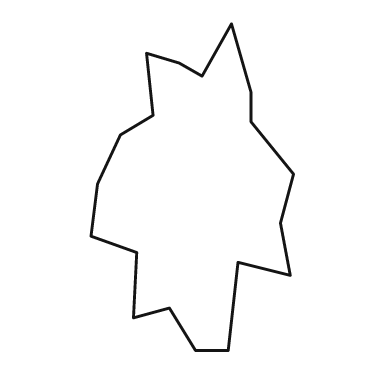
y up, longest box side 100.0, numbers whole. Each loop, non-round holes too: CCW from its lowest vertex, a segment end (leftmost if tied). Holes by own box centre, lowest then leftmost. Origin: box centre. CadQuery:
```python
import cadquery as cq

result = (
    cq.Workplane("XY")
    .moveTo(1.0, -50.0)
    .lineTo(11.0, -50.0)
    .lineTo(14.0, -23.0)
    .lineTo(30.0, -27.0)
    .lineTo(27.0, -11.0)
    .lineTo(31.0, 4.0)
    .lineTo(18.0, 20.0)
    .lineTo(18.0, 29.0)
    .lineTo(12.0, 50.0)
    .lineTo(3.0, 34.0)
    .lineTo(-4.0, 38.0)
    .lineTo(-14.0, 41.0)
    .lineTo(-12.0, 22.0)
    .lineTo(-22.0, 16.0)
    .lineTo(-29.0, 1.0)
    .lineTo(-31.0, -15.0)
    .lineTo(-17.0, -20.0)
    .lineTo(-18.0, -40.0)
    .lineTo(-7.0, -37.0)
    .close()
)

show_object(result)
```